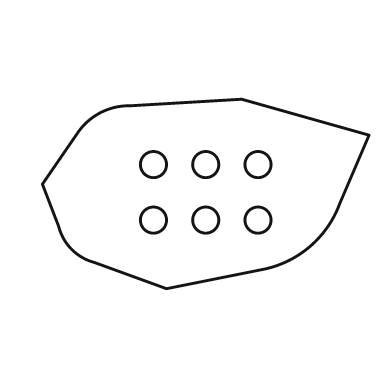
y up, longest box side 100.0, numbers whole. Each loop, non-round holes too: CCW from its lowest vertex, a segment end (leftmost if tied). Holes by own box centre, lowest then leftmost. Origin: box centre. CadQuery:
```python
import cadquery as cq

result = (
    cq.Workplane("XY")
    .moveTo(-12.0, -29.0)
    .lineTo(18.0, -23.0)
    .threePointArc((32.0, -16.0), (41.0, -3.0))
    .lineTo(50.0, 18.0)
    .lineTo(11.0, 29.0)
    .lineTo(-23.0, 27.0)
    .threePointArc((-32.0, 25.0), (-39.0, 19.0))
    .lineTo(-50.0, 3.0)
    .lineTo(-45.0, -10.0)
    .threePointArc((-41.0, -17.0), (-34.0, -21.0))
    .close()
    .moveTo(-16.0, -8.0)
    .circle(4.0)
    .moveTo(0.0, -8.0)
    .circle(4.0)
    .moveTo(16.0, -8.0)
    .circle(4.0)
    .moveTo(-16.0, 9.0)
    .circle(4.0)
    .moveTo(0.0, 9.0)
    .circle(4.0)
    .moveTo(16.0, 9.0)
    .circle(4.0)
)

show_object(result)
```